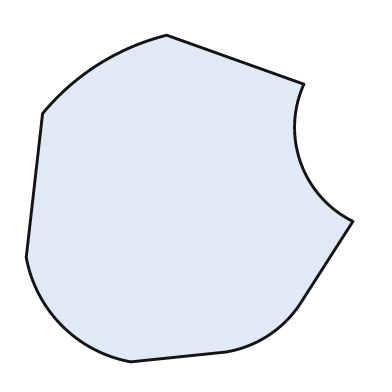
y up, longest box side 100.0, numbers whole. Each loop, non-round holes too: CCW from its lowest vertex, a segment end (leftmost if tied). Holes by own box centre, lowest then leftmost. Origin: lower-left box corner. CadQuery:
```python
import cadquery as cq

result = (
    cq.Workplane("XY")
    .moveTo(32.0, 0.0)
    .lineTo(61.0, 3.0)
    .threePointArc((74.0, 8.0), (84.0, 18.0))
    .lineTo(100.0, 43.0)
    .threePointArc((84.0, 61.0), (85.0, 85.0))
    .lineTo(43.0, 100.0)
    .threePointArc((22.0, 91.0), (5.0, 76.0))
    .lineTo(0.0, 32.0)
    .threePointArc((11.0, 11.0), (32.0, 0.0))
    .close()
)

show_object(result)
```